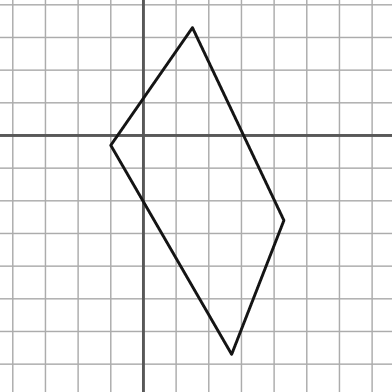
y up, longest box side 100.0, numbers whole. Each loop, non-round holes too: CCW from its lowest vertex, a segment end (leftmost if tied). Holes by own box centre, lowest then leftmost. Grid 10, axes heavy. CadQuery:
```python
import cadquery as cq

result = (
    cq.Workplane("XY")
    .moveTo(27.0, -67.0)
    .lineTo(43.0, -26.0)
    .lineTo(15.0, 33.0)
    .lineTo(-10.0, -3.0)
    .close()
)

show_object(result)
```